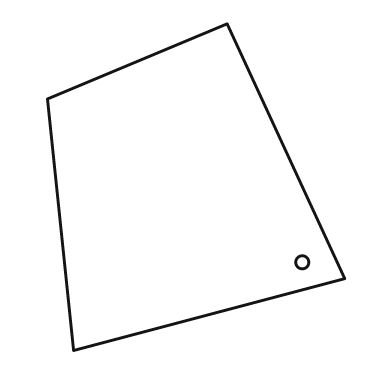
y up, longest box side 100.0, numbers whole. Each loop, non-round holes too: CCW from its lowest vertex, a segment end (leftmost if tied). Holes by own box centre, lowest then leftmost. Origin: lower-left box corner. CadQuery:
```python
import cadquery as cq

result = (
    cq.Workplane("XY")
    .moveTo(8.0, 0.0)
    .lineTo(91.0, 22.0)
    .lineTo(55.0, 100.0)
    .lineTo(0.0, 77.0)
    .close()
    .moveTo(78.0, 27.0)
    .circle(2.0)
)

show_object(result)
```